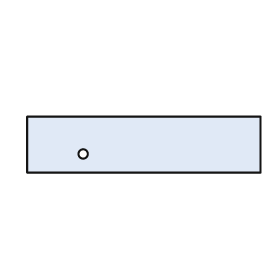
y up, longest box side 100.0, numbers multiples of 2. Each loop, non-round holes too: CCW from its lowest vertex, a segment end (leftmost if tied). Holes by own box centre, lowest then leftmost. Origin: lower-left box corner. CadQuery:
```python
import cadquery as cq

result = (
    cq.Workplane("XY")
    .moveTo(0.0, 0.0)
    .lineTo(100.0, 0.0)
    .lineTo(100.0, 24.0)
    .lineTo(0.0, 24.0)
    .close()
    .moveTo(24.0, 8.0)
    .circle(2.0)
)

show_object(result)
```